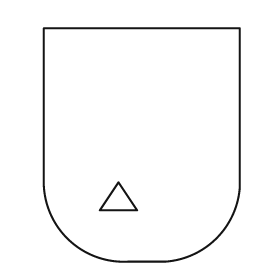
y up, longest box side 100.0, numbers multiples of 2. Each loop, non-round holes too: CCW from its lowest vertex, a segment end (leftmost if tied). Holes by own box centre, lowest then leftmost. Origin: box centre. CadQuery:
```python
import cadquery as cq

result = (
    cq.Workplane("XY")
    .moveTo(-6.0, -50.0)
    .lineTo(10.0, -50.0)
    .threePointArc((32.0, -40.0), (42.0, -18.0))
    .lineTo(42.0, 50.0)
    .lineTo(-42.0, 50.0)
    .lineTo(-42.0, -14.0)
    .threePointArc((-32.0, -40.0), (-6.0, -50.0))
    .close()
    .moveTo(-18.0, -28.0)
    .lineTo(-2.0, -28.0)
    .lineTo(-10.0, -16.0)
    .close()
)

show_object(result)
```